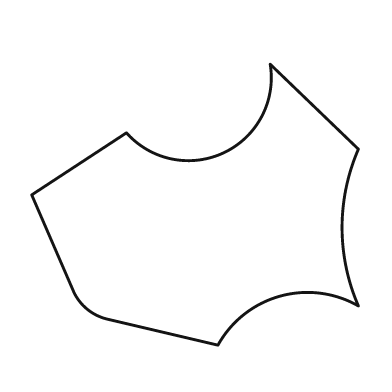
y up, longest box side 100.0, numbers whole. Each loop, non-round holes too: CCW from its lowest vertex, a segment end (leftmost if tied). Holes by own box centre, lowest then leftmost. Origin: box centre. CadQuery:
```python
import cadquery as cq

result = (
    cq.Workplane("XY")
    .moveTo(7.0, -43.0)
    .threePointArc((26.0, -28.0), (50.0, -31.0))
    .threePointArc((45.0, -7.0), (50.0, 17.0))
    .lineTo(23.0, 43.0)
    .threePointArc((9.0, 16.0), (-21.0, 22.0))
    .lineTo(-50.0, 3.0)
    .lineTo(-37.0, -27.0)
    .threePointArc((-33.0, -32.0), (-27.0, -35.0))
    .close()
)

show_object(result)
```